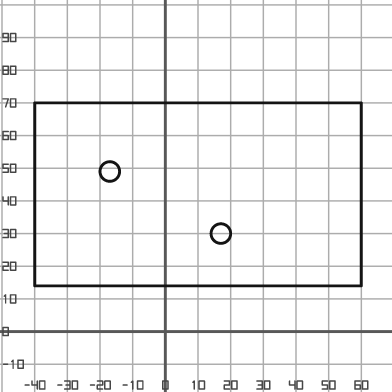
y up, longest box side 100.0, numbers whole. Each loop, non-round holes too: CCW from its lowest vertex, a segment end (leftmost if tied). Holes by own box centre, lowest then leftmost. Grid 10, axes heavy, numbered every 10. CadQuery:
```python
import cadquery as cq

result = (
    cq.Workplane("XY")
    .moveTo(-40.0, 14.0)
    .lineTo(60.0, 14.0)
    .lineTo(60.0, 70.0)
    .lineTo(-40.0, 70.0)
    .close()
    .moveTo(17.0, 30.0)
    .circle(3.0)
    .moveTo(-17.0, 49.0)
    .circle(3.0)
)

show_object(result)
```